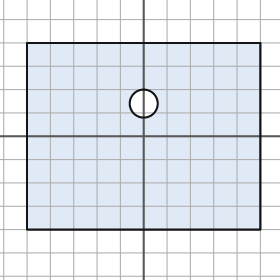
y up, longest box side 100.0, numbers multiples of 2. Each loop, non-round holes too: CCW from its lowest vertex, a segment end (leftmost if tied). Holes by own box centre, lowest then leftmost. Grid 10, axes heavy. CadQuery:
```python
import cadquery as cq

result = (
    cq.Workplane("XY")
    .moveTo(-50.0, -40.0)
    .lineTo(50.0, -40.0)
    .lineTo(50.0, 40.0)
    .lineTo(-50.0, 40.0)
    .close()
    .moveTo(0.0, 14.0)
    .circle(6.0)
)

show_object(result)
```